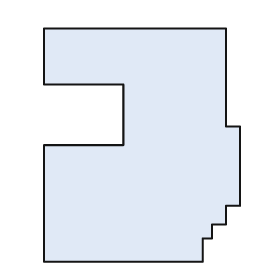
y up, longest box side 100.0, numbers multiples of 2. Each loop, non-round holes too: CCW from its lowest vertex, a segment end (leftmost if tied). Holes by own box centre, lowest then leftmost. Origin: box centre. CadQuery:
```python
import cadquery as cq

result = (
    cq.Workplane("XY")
    .moveTo(-42.0, -50.0)
    .lineTo(26.0, -50.0)
    .lineTo(26.0, -40.0)
    .lineTo(30.0, -40.0)
    .lineTo(30.0, -34.0)
    .lineTo(36.0, -34.0)
    .lineTo(36.0, -26.0)
    .lineTo(42.0, -26.0)
    .lineTo(42.0, 8.0)
    .lineTo(36.0, 8.0)
    .lineTo(36.0, 50.0)
    .lineTo(-42.0, 50.0)
    .lineTo(-42.0, 26.0)
    .lineTo(-8.0, 26.0)
    .lineTo(-8.0, 0.0)
    .lineTo(-42.0, 0.0)
    .close()
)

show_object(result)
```